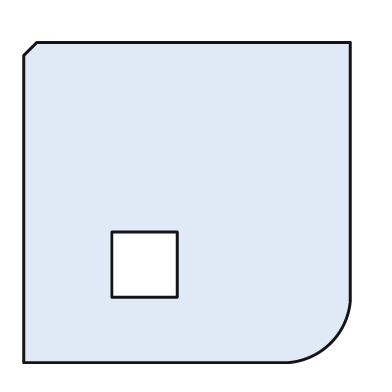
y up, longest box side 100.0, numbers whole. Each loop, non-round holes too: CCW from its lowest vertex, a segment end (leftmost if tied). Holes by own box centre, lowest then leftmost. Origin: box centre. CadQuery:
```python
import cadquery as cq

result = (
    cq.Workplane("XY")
    .moveTo(-50.0, -49.0)
    .lineTo(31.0, -49.0)
    .threePointArc((44.0, -43.0), (50.0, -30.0))
    .lineTo(50.0, 49.0)
    .lineTo(-46.0, 49.0)
    .lineTo(-50.0, 45.0)
    .close()
    .moveTo(-23.0, -29.0)
    .lineTo(-3.0, -29.0)
    .lineTo(-3.0, -9.0)
    .lineTo(-23.0, -9.0)
    .close()
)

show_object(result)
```